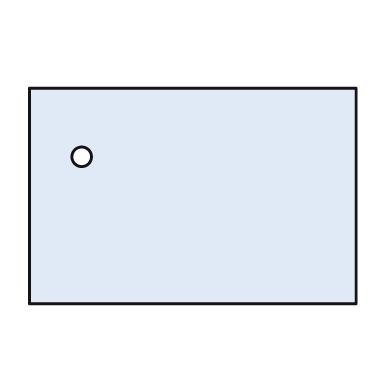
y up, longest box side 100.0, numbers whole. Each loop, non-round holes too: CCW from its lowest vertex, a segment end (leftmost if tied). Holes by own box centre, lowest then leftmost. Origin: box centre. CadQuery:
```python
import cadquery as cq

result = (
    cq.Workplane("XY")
    .moveTo(-50.0, -33.0)
    .lineTo(50.0, -33.0)
    .lineTo(50.0, 33.0)
    .lineTo(-50.0, 33.0)
    .close()
    .moveTo(-34.0, 12.0)
    .circle(3.0)
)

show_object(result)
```